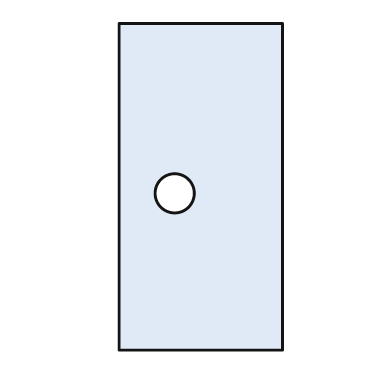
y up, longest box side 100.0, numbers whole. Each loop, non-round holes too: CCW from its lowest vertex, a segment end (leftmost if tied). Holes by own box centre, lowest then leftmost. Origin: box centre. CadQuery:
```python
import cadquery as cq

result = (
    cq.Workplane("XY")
    .moveTo(-25.0, -50.0)
    .lineTo(25.0, -50.0)
    .lineTo(25.0, 50.0)
    .lineTo(-25.0, 50.0)
    .close()
    .moveTo(-8.0, -2.0)
    .circle(6.0)
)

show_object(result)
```